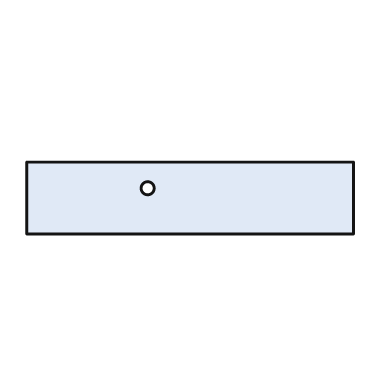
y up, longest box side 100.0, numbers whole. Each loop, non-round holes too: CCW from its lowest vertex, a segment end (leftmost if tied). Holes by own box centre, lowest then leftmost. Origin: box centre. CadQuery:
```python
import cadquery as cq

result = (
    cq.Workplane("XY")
    .moveTo(-50.0, -11.0)
    .lineTo(50.0, -11.0)
    .lineTo(50.0, 11.0)
    .lineTo(-50.0, 11.0)
    .close()
    .moveTo(-13.0, 3.0)
    .circle(2.0)
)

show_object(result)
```